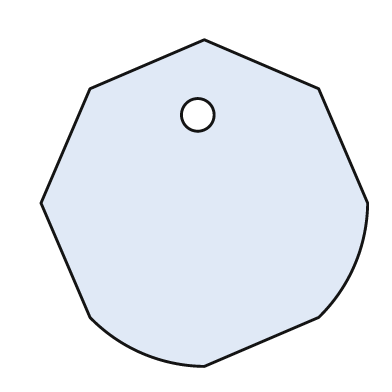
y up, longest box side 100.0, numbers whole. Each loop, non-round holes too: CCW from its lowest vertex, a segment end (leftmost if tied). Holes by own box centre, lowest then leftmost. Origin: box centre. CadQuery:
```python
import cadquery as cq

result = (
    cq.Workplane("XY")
    .moveTo(0.0, -50.0)
    .lineTo(35.0, -35.0)
    .threePointArc((46.0, -19.0), (50.0, 0.0))
    .lineTo(35.0, 35.0)
    .lineTo(0.0, 50.0)
    .lineTo(-35.0, 35.0)
    .lineTo(-50.0, 0.0)
    .lineTo(-35.0, -35.0)
    .threePointArc((-19.0, -46.0), (0.0, -50.0))
    .close()
    .moveTo(-2.0, 27.0)
    .circle(5.0)
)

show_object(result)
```